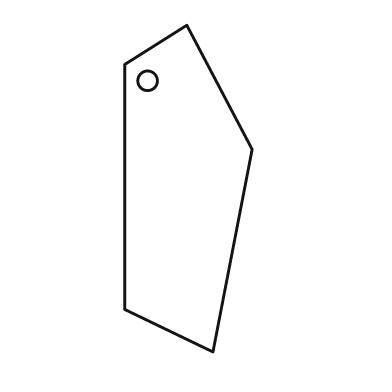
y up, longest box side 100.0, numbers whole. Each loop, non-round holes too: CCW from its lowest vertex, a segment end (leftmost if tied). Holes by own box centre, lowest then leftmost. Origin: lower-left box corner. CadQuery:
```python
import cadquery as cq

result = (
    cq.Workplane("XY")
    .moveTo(27.0, 0.0)
    .lineTo(39.0, 62.0)
    .lineTo(19.0, 100.0)
    .lineTo(0.0, 88.0)
    .lineTo(0.0, 13.0)
    .close()
    .moveTo(7.0, 83.0)
    .circle(3.0)
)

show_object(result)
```